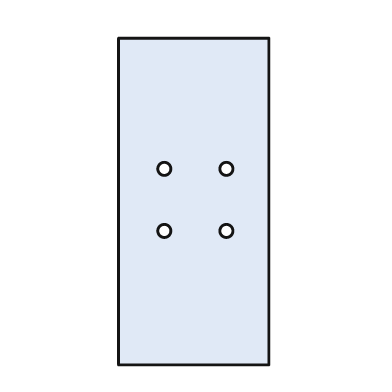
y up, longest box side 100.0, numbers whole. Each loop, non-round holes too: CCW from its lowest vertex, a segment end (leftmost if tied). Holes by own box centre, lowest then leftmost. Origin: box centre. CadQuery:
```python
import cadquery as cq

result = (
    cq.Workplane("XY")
    .moveTo(-23.0, -50.0)
    .lineTo(23.0, -50.0)
    .lineTo(23.0, 50.0)
    .lineTo(-23.0, 50.0)
    .close()
    .moveTo(-9.0, -9.0)
    .circle(2.0)
    .moveTo(10.0, -9.0)
    .circle(2.0)
    .moveTo(-9.0, 10.0)
    .circle(2.0)
    .moveTo(10.0, 10.0)
    .circle(2.0)
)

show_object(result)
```